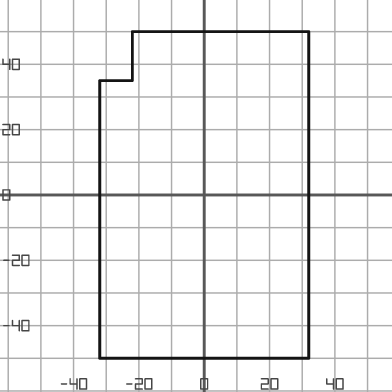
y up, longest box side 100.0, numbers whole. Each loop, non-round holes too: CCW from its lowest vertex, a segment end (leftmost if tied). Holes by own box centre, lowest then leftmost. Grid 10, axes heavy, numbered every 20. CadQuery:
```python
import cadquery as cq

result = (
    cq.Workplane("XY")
    .moveTo(-32.0, -50.0)
    .lineTo(32.0, -50.0)
    .lineTo(32.0, 50.0)
    .lineTo(-22.0, 50.0)
    .lineTo(-22.0, 35.0)
    .lineTo(-32.0, 35.0)
    .close()
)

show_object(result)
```